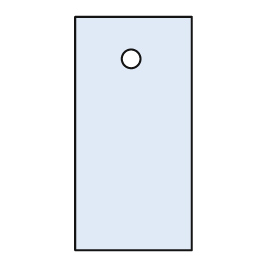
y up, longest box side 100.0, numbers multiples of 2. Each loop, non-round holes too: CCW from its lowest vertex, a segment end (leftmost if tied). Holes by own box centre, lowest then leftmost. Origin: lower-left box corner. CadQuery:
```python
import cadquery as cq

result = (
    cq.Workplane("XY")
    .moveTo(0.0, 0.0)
    .lineTo(50.0, 0.0)
    .lineTo(50.0, 100.0)
    .lineTo(0.0, 100.0)
    .close()
    .moveTo(24.0, 82.0)
    .circle(4.0)
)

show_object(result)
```